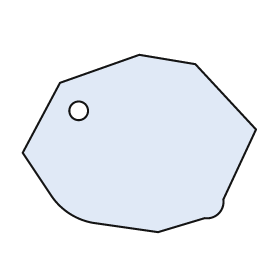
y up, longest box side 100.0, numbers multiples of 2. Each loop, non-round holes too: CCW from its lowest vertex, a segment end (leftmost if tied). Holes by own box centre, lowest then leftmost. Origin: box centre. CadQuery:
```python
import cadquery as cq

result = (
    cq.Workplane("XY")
    .moveTo(8.0, -38.0)
    .lineTo(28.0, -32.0)
    .threePointArc((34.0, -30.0), (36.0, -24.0))
    .lineTo(50.0, 6.0)
    .lineTo(24.0, 34.0)
    .lineTo(0.0, 38.0)
    .lineTo(-34.0, 26.0)
    .lineTo(-50.0, -4.0)
    .lineTo(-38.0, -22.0)
    .threePointArc((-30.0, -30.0), (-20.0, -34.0))
    .close()
    .moveTo(-26.0, 14.0)
    .circle(4.0)
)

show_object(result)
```